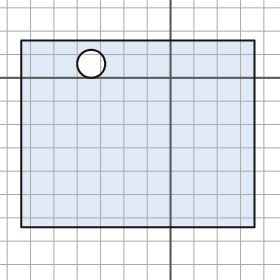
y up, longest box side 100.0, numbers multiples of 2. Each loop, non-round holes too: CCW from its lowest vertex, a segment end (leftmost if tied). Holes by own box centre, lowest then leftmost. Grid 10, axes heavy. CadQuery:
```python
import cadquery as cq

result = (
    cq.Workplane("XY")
    .moveTo(-64.0, -64.0)
    .lineTo(36.0, -64.0)
    .lineTo(36.0, 16.0)
    .lineTo(-64.0, 16.0)
    .close()
    .moveTo(-34.0, 6.0)
    .circle(6.0)
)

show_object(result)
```